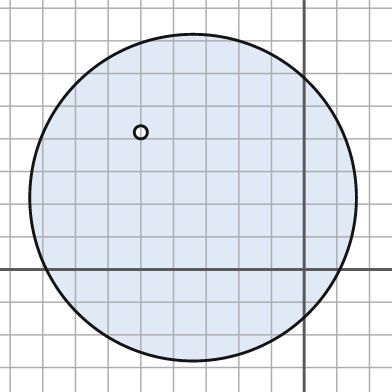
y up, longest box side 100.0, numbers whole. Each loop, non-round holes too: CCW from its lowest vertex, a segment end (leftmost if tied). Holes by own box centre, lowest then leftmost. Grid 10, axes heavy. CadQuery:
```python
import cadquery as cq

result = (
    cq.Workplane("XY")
    .moveTo(-34.0, 22.0)
    .circle(50.0)
    .moveTo(-50.0, 42.0)
    .circle(2.0)
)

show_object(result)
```